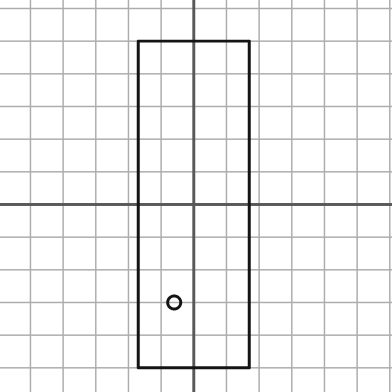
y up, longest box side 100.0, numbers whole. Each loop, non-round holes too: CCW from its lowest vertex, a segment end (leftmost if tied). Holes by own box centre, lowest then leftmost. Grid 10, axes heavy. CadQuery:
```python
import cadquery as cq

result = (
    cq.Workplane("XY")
    .moveTo(-17.0, -50.0)
    .lineTo(17.0, -50.0)
    .lineTo(17.0, 50.0)
    .lineTo(-17.0, 50.0)
    .close()
    .moveTo(-6.0, -30.0)
    .circle(2.0)
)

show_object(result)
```